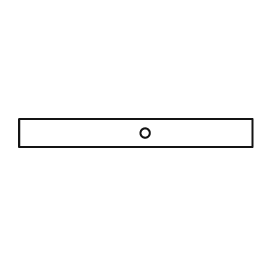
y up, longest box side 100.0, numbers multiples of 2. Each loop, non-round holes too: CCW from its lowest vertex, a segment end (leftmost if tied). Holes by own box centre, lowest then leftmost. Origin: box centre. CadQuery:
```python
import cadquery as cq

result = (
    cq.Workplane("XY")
    .moveTo(-50.0, -6.0)
    .lineTo(50.0, -6.0)
    .lineTo(50.0, 6.0)
    .lineTo(-50.0, 6.0)
    .close()
    .moveTo(4.0, 0.0)
    .circle(2.0)
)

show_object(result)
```